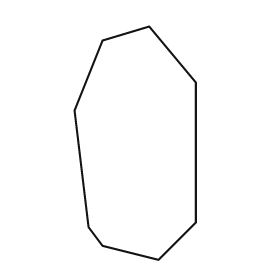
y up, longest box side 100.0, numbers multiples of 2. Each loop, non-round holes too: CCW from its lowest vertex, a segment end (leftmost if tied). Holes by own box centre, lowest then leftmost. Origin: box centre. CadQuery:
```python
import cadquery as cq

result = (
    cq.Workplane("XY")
    .moveTo(10.0, -50.0)
    .lineTo(26.0, -34.0)
    .lineTo(26.0, 26.0)
    .lineTo(6.0, 50.0)
    .lineTo(-14.0, 44.0)
    .lineTo(-26.0, 14.0)
    .lineTo(-20.0, -36.0)
    .lineTo(-14.0, -44.0)
    .close()
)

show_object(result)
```